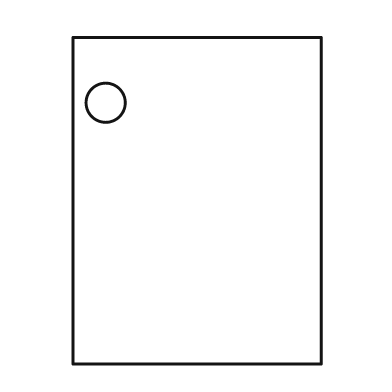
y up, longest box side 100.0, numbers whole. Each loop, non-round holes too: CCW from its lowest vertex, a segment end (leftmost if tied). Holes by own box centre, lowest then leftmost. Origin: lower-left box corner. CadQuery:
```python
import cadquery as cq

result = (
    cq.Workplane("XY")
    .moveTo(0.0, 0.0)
    .lineTo(76.0, 0.0)
    .lineTo(76.0, 100.0)
    .lineTo(0.0, 100.0)
    .close()
    .moveTo(10.0, 80.0)
    .circle(6.0)
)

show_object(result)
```